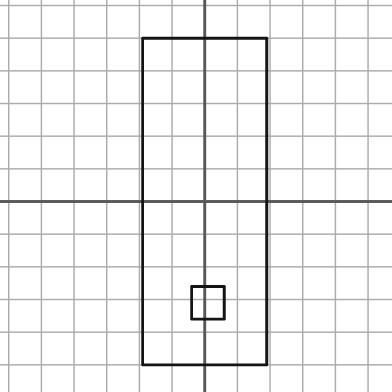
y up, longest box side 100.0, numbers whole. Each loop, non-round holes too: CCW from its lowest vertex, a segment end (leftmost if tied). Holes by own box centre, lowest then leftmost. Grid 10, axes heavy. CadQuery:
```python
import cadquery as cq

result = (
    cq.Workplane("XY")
    .moveTo(-19.0, -50.0)
    .lineTo(19.0, -50.0)
    .lineTo(19.0, 50.0)
    .lineTo(-19.0, 50.0)
    .close()
    .moveTo(-4.0, -36.0)
    .lineTo(6.0, -36.0)
    .lineTo(6.0, -26.0)
    .lineTo(-4.0, -26.0)
    .close()
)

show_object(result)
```